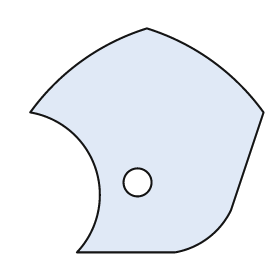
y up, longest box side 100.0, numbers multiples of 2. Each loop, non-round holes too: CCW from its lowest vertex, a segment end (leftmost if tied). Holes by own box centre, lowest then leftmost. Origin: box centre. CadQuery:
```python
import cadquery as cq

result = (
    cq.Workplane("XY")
    .moveTo(-30.0, -48.0)
    .lineTo(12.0, -48.0)
    .threePointArc((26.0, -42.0), (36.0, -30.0))
    .lineTo(50.0, 12.0)
    .threePointArc((28.0, 34.0), (0.0, 48.0))
    .threePointArc((-28.0, 34.0), (-50.0, 12.0))
    .threePointArc((-22.0, -12.0), (-30.0, -48.0))
    .close()
    .moveTo(-4.0, -18.0)
    .circle(6.0)
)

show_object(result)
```